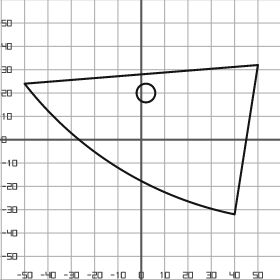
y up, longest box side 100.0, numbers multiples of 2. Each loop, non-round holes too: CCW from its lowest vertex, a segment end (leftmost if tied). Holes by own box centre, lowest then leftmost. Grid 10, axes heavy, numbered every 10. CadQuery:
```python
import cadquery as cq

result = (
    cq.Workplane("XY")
    .moveTo(40.0, -32.0)
    .lineTo(50.0, 32.0)
    .lineTo(-50.0, 24.0)
    .threePointArc((-10.0, -12.0), (40.0, -32.0))
    .close()
    .moveTo(2.0, 20.0)
    .circle(4.0)
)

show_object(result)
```